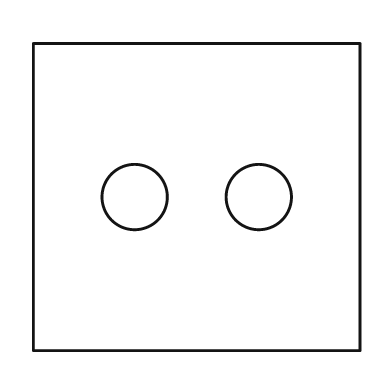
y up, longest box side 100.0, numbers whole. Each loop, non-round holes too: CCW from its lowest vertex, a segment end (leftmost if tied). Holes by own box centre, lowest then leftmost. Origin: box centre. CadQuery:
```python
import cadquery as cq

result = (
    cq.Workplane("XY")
    .moveTo(-50.0, -47.0)
    .lineTo(50.0, -47.0)
    .lineTo(50.0, 47.0)
    .lineTo(-50.0, 47.0)
    .close()
    .moveTo(-19.0, 0.0)
    .circle(10.0)
    .moveTo(19.0, 0.0)
    .circle(10.0)
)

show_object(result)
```